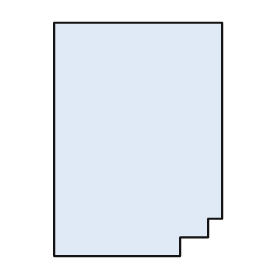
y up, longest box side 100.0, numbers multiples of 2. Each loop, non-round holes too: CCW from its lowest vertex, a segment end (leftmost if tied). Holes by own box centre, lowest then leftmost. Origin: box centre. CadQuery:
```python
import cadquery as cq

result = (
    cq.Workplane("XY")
    .moveTo(-36.0, -50.0)
    .lineTo(18.0, -50.0)
    .lineTo(18.0, -42.0)
    .lineTo(30.0, -42.0)
    .lineTo(30.0, -34.0)
    .lineTo(36.0, -34.0)
    .lineTo(36.0, 50.0)
    .lineTo(-36.0, 50.0)
    .close()
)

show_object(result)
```